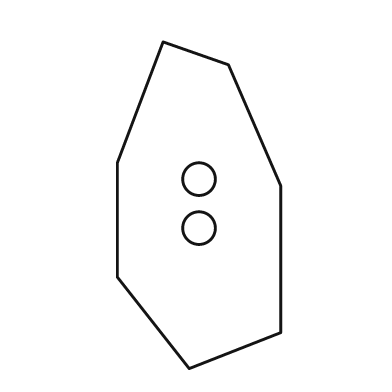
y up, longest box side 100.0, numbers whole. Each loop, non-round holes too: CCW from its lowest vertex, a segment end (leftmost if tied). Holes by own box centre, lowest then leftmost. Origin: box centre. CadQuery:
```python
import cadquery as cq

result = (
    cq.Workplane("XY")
    .moveTo(-3.0, -50.0)
    .lineTo(25.0, -39.0)
    .lineTo(25.0, 6.0)
    .lineTo(9.0, 43.0)
    .lineTo(-11.0, 50.0)
    .lineTo(-25.0, 13.0)
    .lineTo(-25.0, -22.0)
    .close()
    .moveTo(0.0, -7.0)
    .circle(5.0)
    .moveTo(0.0, 8.0)
    .circle(5.0)
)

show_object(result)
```